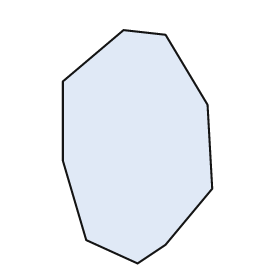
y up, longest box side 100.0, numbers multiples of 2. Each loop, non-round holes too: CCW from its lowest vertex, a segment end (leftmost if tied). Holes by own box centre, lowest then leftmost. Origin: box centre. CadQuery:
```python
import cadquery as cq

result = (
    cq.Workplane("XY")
    .moveTo(0.0, -50.0)
    .lineTo(12.0, -42.0)
    .lineTo(32.0, -18.0)
    .lineTo(30.0, 18.0)
    .lineTo(12.0, 48.0)
    .lineTo(-6.0, 50.0)
    .lineTo(-32.0, 28.0)
    .lineTo(-32.0, -6.0)
    .lineTo(-22.0, -40.0)
    .close()
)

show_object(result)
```